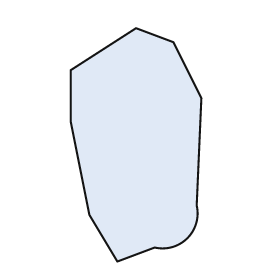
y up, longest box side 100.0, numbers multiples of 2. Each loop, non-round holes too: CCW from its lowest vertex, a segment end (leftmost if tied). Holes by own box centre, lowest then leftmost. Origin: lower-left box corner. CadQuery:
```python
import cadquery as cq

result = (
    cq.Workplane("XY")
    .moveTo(20.0, 0.0)
    .lineTo(36.0, 6.0)
    .threePointArc((50.0, 10.0), (54.0, 24.0))
    .lineTo(56.0, 70.0)
    .lineTo(44.0, 94.0)
    .lineTo(28.0, 100.0)
    .lineTo(0.0, 82.0)
    .lineTo(0.0, 60.0)
    .lineTo(8.0, 20.0)
    .close()
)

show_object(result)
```